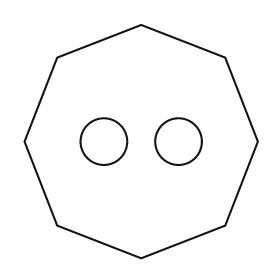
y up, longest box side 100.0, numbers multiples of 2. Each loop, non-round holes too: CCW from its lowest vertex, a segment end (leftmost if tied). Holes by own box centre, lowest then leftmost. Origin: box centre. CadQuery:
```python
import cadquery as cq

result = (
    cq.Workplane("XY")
    .moveTo(0.0, -50.0)
    .lineTo(36.0, -36.0)
    .lineTo(50.0, 0.0)
    .lineTo(36.0, 36.0)
    .lineTo(0.0, 50.0)
    .lineTo(-36.0, 36.0)
    .lineTo(-50.0, 0.0)
    .lineTo(-36.0, -36.0)
    .close()
    .moveTo(-16.0, 0.0)
    .circle(10.0)
    .moveTo(16.0, 0.0)
    .circle(10.0)
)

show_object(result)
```